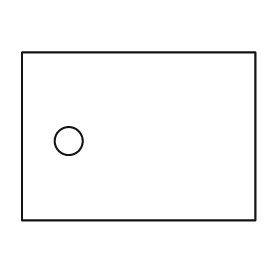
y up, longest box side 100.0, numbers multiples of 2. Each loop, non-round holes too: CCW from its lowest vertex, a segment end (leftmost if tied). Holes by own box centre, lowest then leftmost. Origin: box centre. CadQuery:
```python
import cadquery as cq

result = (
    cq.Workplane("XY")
    .moveTo(-50.0, -36.0)
    .lineTo(50.0, -36.0)
    .lineTo(50.0, 36.0)
    .lineTo(-50.0, 36.0)
    .close()
    .moveTo(-30.0, -2.0)
    .circle(6.0)
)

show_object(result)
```